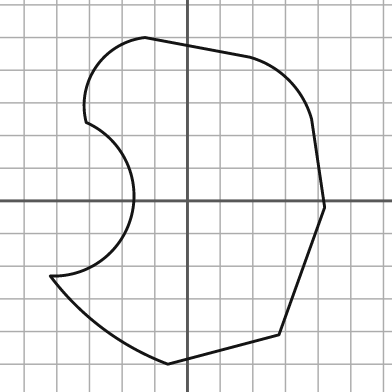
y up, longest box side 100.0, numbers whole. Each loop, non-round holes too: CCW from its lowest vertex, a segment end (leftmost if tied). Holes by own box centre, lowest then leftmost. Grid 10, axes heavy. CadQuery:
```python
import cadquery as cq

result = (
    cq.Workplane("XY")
    .moveTo(-6.0, -50.0)
    .lineTo(28.0, -41.0)
    .lineTo(42.0, -2.0)
    .lineTo(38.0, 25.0)
    .threePointArc((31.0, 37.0), (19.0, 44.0))
    .lineTo(-13.0, 50.0)
    .threePointArc((-28.0, 41.0), (-31.0, 24.0))
    .threePointArc((-17.0, -4.0), (-42.0, -23.0))
    .threePointArc((-26.0, -39.0), (-6.0, -50.0))
    .close()
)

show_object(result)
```